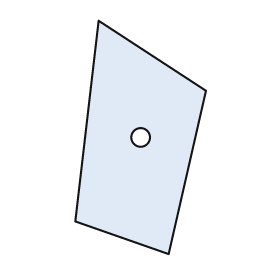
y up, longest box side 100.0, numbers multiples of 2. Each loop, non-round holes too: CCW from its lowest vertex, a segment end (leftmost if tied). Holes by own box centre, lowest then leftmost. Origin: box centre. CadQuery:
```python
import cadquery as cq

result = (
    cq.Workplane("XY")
    .moveTo(12.0, -50.0)
    .lineTo(28.0, 20.0)
    .lineTo(-18.0, 50.0)
    .lineTo(-28.0, -36.0)
    .close()
    .moveTo(0.0, 0.0)
    .circle(4.0)
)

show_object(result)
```